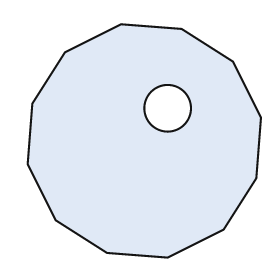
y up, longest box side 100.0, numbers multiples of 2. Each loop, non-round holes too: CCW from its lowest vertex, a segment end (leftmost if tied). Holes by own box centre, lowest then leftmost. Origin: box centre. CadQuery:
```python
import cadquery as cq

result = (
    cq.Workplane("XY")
    .moveTo(10.0, -50.0)
    .lineTo(34.0, -38.0)
    .lineTo(48.0, -16.0)
    .lineTo(50.0, 10.0)
    .lineTo(38.0, 34.0)
    .lineTo(16.0, 48.0)
    .lineTo(-10.0, 50.0)
    .lineTo(-34.0, 38.0)
    .lineTo(-48.0, 16.0)
    .lineTo(-50.0, -10.0)
    .lineTo(-38.0, -34.0)
    .lineTo(-16.0, -48.0)
    .close()
    .moveTo(10.0, 14.0)
    .circle(10.0)
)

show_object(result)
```